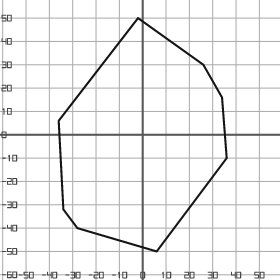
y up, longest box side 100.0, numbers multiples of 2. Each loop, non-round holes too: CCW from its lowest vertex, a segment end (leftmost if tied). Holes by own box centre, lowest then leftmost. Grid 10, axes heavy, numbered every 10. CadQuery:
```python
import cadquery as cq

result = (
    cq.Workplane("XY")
    .moveTo(6.0, -50.0)
    .lineTo(36.0, -10.0)
    .lineTo(34.0, 16.0)
    .lineTo(26.0, 30.0)
    .lineTo(-2.0, 50.0)
    .lineTo(-36.0, 6.0)
    .lineTo(-34.0, -32.0)
    .lineTo(-28.0, -40.0)
    .close()
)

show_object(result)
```